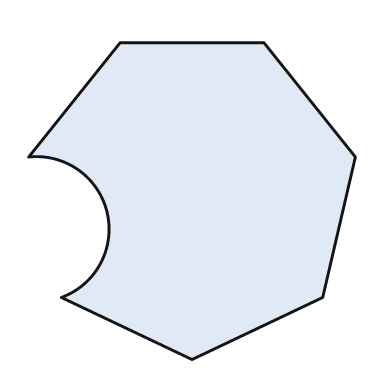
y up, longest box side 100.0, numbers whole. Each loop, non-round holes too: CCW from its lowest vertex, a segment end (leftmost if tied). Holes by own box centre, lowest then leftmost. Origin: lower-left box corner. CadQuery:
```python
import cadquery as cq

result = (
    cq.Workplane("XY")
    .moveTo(50.0, 0.0)
    .lineTo(90.0, 19.0)
    .lineTo(100.0, 62.0)
    .lineTo(72.0, 97.0)
    .lineTo(28.0, 97.0)
    .lineTo(0.0, 62.0)
    .threePointArc((24.0, 45.0), (10.0, 19.0))
    .close()
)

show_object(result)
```